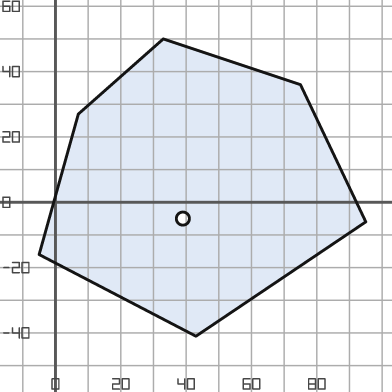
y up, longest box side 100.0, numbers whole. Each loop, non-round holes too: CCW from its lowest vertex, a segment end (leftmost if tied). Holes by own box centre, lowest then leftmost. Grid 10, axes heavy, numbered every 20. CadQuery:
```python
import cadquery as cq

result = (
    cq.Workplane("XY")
    .moveTo(43.0, -41.0)
    .lineTo(95.0, -6.0)
    .lineTo(75.0, 36.0)
    .lineTo(33.0, 50.0)
    .lineTo(7.0, 27.0)
    .lineTo(-5.0, -16.0)
    .close()
    .moveTo(39.0, -5.0)
    .circle(2.0)
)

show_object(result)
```